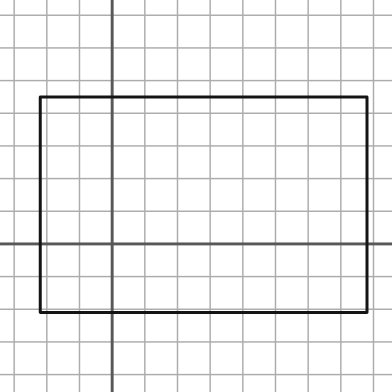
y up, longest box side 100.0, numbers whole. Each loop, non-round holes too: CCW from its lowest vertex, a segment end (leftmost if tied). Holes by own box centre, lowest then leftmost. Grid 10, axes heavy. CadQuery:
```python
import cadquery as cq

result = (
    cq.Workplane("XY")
    .moveTo(-22.0, -21.0)
    .lineTo(78.0, -21.0)
    .lineTo(78.0, 45.0)
    .lineTo(-22.0, 45.0)
    .close()
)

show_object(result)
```